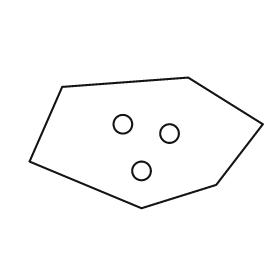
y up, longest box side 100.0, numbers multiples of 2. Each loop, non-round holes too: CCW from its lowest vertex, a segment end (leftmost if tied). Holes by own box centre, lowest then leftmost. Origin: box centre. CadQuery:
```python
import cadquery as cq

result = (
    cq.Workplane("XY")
    .moveTo(-2.0, -28.0)
    .lineTo(30.0, -18.0)
    .lineTo(50.0, 8.0)
    .lineTo(18.0, 28.0)
    .lineTo(-36.0, 24.0)
    .lineTo(-50.0, -8.0)
    .close()
    .moveTo(-2.0, -12.0)
    .circle(4.0)
    .moveTo(10.0, 4.0)
    .circle(4.0)
    .moveTo(-10.0, 8.0)
    .circle(4.0)
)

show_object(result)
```